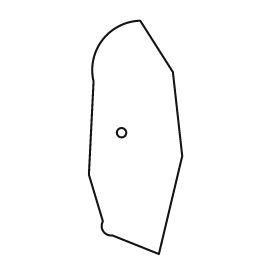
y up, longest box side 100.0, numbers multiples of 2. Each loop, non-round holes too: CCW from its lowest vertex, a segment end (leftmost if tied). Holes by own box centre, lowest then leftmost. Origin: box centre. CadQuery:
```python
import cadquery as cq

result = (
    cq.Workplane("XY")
    .moveTo(10.0, -50.0)
    .lineTo(20.0, -8.0)
    .lineTo(16.0, 28.0)
    .lineTo(2.0, 50.0)
    .threePointArc((-14.0, 42.0), (-18.0, 24.0))
    .lineTo(-20.0, -16.0)
    .lineTo(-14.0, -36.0)
    .threePointArc((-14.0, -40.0), (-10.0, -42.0))
    .close()
    .moveTo(-6.0, 2.0)
    .circle(2.0)
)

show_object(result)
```